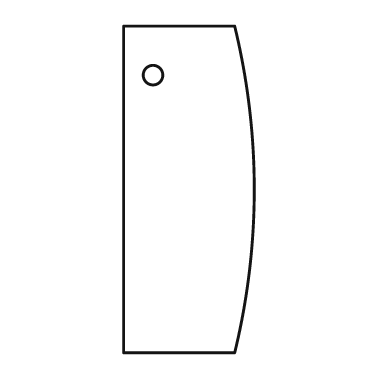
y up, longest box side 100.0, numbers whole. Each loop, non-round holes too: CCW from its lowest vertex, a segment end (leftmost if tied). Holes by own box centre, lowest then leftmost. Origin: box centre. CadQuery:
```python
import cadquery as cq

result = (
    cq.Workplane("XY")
    .moveTo(-20.0, -50.0)
    .lineTo(14.0, -50.0)
    .threePointArc((20.0, 0.0), (14.0, 50.0))
    .lineTo(-20.0, 50.0)
    .close()
    .moveTo(-11.0, 35.0)
    .circle(3.0)
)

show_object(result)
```